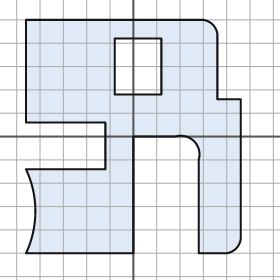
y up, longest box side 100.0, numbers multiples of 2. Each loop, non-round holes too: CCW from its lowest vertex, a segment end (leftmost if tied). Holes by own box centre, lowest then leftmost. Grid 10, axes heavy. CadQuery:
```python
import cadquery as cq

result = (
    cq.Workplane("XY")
    .moveTo(-46.0, -50.0)
    .lineTo(0.0, -50.0)
    .lineTo(0.0, 0.0)
    .lineTo(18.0, 0.0)
    .threePointArc((26.0, -2.0), (28.0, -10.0))
    .lineTo(28.0, -50.0)
    .lineTo(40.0, -50.0)
    .threePointArc((44.0, -48.0), (46.0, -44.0))
    .lineTo(46.0, 16.0)
    .lineTo(36.0, 16.0)
    .lineTo(36.0, 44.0)
    .threePointArc((34.0, 48.0), (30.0, 50.0))
    .lineTo(-46.0, 50.0)
    .lineTo(-46.0, 6.0)
    .lineTo(-12.0, 6.0)
    .lineTo(-12.0, -14.0)
    .lineTo(-46.0, -14.0)
    .threePointArc((-42.0, -32.0), (-46.0, -50.0))
    .close()
    .moveTo(-8.0, 18.0)
    .lineTo(12.0, 18.0)
    .lineTo(12.0, 42.0)
    .lineTo(-8.0, 42.0)
    .close()
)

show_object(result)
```